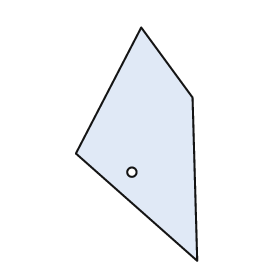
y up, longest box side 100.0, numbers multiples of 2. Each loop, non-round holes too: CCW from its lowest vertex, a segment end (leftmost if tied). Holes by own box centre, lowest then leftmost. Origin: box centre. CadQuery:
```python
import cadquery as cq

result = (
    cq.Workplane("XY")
    .moveTo(26.0, -50.0)
    .lineTo(24.0, 20.0)
    .lineTo(2.0, 50.0)
    .lineTo(-26.0, -4.0)
    .close()
    .moveTo(-2.0, -12.0)
    .circle(2.0)
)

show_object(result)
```